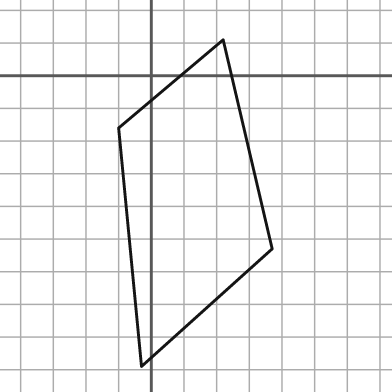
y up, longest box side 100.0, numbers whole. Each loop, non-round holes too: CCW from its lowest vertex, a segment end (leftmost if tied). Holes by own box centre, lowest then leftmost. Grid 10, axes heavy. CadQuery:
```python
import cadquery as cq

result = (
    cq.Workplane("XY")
    .moveTo(-3.0, -89.0)
    .lineTo(37.0, -53.0)
    .lineTo(22.0, 11.0)
    .lineTo(-10.0, -16.0)
    .close()
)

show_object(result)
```